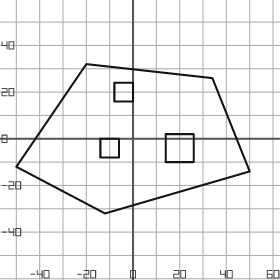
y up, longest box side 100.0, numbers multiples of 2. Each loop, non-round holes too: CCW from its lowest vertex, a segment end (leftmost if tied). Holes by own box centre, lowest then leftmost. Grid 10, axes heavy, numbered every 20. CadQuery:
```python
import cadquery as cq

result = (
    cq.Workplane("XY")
    .moveTo(-12.0, -32.0)
    .lineTo(50.0, -14.0)
    .lineTo(34.0, 26.0)
    .lineTo(-20.0, 32.0)
    .lineTo(-50.0, -12.0)
    .close()
    .moveTo(-14.0, -8.0)
    .lineTo(-6.0, -8.0)
    .lineTo(-6.0, 0.0)
    .lineTo(-14.0, 0.0)
    .close()
    .moveTo(14.0, -10.0)
    .lineTo(26.0, -10.0)
    .lineTo(26.0, 2.0)
    .lineTo(14.0, 2.0)
    .close()
    .moveTo(-8.0, 16.0)
    .lineTo(0.0, 16.0)
    .lineTo(0.0, 24.0)
    .lineTo(-8.0, 24.0)
    .close()
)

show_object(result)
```